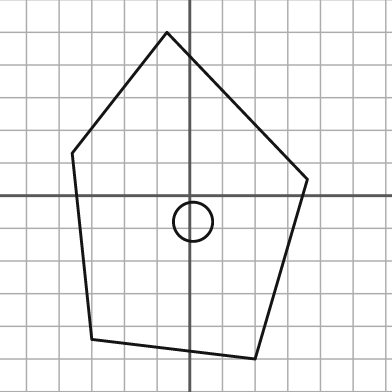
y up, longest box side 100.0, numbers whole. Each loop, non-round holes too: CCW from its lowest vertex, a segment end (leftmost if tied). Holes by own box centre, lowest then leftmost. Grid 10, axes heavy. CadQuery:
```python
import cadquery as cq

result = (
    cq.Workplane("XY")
    .moveTo(20.0, -50.0)
    .lineTo(36.0, 5.0)
    .lineTo(-7.0, 50.0)
    .lineTo(-36.0, 13.0)
    .lineTo(-30.0, -44.0)
    .close()
    .moveTo(1.0, -8.0)
    .circle(6.0)
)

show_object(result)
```